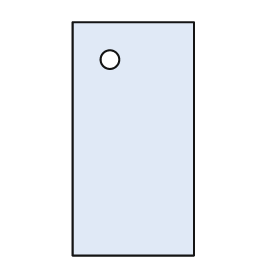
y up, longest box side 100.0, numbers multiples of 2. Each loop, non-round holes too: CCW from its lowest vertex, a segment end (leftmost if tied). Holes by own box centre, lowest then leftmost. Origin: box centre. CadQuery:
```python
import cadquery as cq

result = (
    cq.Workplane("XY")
    .moveTo(-26.0, -50.0)
    .lineTo(26.0, -50.0)
    .lineTo(26.0, 50.0)
    .lineTo(-26.0, 50.0)
    .close()
    .moveTo(-10.0, 34.0)
    .circle(4.0)
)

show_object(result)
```